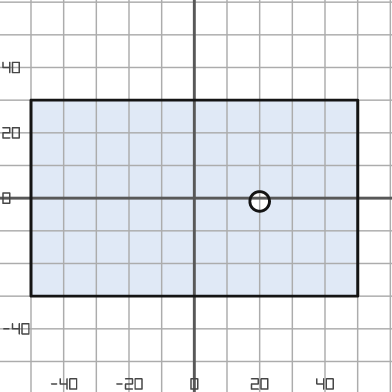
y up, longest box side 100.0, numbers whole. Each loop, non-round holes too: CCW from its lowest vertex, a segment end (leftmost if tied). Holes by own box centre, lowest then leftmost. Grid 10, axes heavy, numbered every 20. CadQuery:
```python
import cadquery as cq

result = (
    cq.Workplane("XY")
    .moveTo(-50.0, -30.0)
    .lineTo(50.0, -30.0)
    .lineTo(50.0, 30.0)
    .lineTo(-50.0, 30.0)
    .close()
    .moveTo(20.0, -1.0)
    .circle(3.0)
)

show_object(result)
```